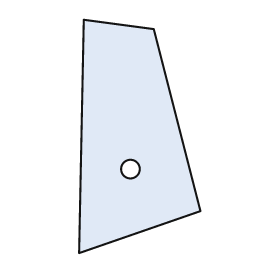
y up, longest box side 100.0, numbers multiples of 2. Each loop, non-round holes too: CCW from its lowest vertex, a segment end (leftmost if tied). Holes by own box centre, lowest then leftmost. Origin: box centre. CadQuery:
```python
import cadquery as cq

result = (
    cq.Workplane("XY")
    .moveTo(-26.0, -50.0)
    .lineTo(26.0, -32.0)
    .lineTo(6.0, 46.0)
    .lineTo(-24.0, 50.0)
    .close()
    .moveTo(-4.0, -14.0)
    .circle(4.0)
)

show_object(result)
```